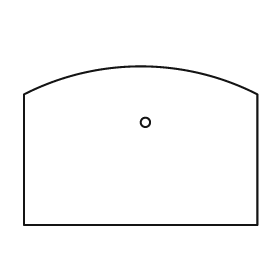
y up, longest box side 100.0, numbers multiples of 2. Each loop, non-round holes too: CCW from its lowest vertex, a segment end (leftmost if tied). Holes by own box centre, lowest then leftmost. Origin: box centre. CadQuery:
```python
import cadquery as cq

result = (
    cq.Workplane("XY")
    .moveTo(-50.0, -34.0)
    .lineTo(50.0, -34.0)
    .lineTo(50.0, 22.0)
    .threePointArc((0.0, 34.0), (-50.0, 22.0))
    .close()
    .moveTo(2.0, 10.0)
    .circle(2.0)
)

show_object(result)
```